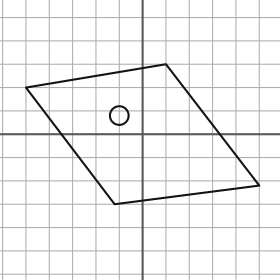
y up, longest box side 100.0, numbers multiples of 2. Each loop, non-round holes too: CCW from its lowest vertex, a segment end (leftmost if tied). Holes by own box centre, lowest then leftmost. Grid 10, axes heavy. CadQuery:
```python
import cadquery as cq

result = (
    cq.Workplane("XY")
    .moveTo(-12.0, -30.0)
    .lineTo(50.0, -22.0)
    .lineTo(10.0, 30.0)
    .lineTo(-50.0, 20.0)
    .close()
    .moveTo(-10.0, 8.0)
    .circle(4.0)
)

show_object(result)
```